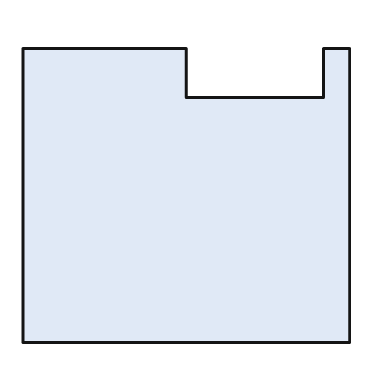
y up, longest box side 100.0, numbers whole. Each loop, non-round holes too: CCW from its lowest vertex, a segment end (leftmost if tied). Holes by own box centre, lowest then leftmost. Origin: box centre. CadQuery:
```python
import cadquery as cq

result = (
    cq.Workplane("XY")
    .moveTo(-50.0, -45.0)
    .lineTo(50.0, -45.0)
    .lineTo(50.0, 45.0)
    .lineTo(42.0, 45.0)
    .lineTo(42.0, 30.0)
    .lineTo(0.0, 30.0)
    .lineTo(0.0, 45.0)
    .lineTo(-50.0, 45.0)
    .close()
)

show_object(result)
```